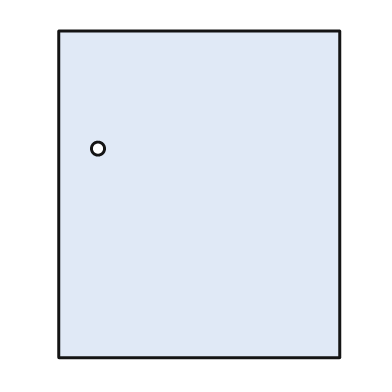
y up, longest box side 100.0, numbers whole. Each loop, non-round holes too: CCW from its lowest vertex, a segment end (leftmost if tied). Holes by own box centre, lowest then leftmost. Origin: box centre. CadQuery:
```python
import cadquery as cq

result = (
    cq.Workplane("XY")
    .moveTo(-43.0, -50.0)
    .lineTo(43.0, -50.0)
    .lineTo(43.0, 50.0)
    .lineTo(-43.0, 50.0)
    .close()
    .moveTo(-31.0, 14.0)
    .circle(2.0)
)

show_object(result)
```